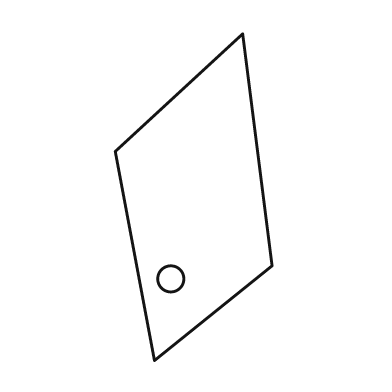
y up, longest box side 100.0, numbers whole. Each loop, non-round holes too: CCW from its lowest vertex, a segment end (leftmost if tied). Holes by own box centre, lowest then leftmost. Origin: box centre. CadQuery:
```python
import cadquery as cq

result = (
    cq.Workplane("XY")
    .moveTo(-12.0, -50.0)
    .lineTo(24.0, -21.0)
    .lineTo(15.0, 50.0)
    .lineTo(-24.0, 14.0)
    .close()
    .moveTo(-7.0, -25.0)
    .circle(4.0)
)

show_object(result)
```